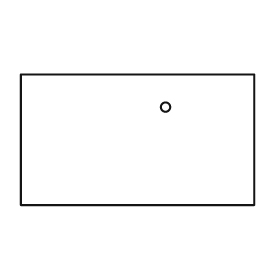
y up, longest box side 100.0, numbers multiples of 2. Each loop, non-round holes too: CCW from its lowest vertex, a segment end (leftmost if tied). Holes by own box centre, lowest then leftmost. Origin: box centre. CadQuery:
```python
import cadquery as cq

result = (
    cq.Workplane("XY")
    .moveTo(-50.0, -28.0)
    .lineTo(50.0, -28.0)
    .lineTo(50.0, 28.0)
    .lineTo(-50.0, 28.0)
    .close()
    .moveTo(12.0, 14.0)
    .circle(2.0)
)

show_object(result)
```